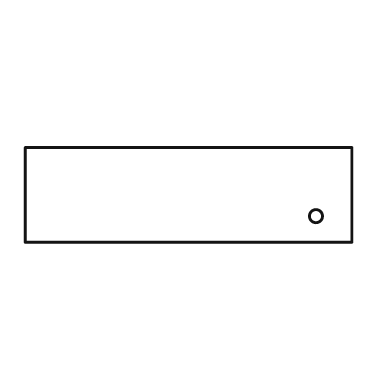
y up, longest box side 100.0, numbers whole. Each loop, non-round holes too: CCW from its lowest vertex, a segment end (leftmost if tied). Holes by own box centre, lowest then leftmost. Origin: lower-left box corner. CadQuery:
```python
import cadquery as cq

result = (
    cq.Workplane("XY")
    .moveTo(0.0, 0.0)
    .lineTo(100.0, 0.0)
    .lineTo(100.0, 29.0)
    .lineTo(0.0, 29.0)
    .close()
    .moveTo(89.0, 8.0)
    .circle(2.0)
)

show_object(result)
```